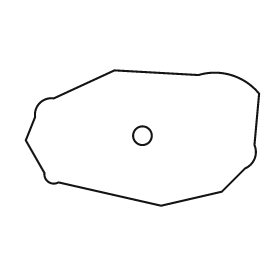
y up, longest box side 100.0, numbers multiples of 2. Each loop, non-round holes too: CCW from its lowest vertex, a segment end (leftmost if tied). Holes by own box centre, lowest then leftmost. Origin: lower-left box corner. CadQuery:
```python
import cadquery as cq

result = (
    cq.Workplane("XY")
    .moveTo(58.0, 0.0)
    .lineTo(84.0, 6.0)
    .lineTo(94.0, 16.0)
    .threePointArc((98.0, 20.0), (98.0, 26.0))
    .lineTo(100.0, 48.0)
    .threePointArc((88.0, 56.0), (74.0, 56.0))
    .lineTo(38.0, 58.0)
    .lineTo(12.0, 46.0)
    .threePointArc((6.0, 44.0), (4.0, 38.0))
    .lineTo(0.0, 28.0)
    .lineTo(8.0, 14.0)
    .threePointArc((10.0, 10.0), (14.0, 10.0))
    .close()
    .moveTo(50.0, 30.0)
    .circle(4.0)
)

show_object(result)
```